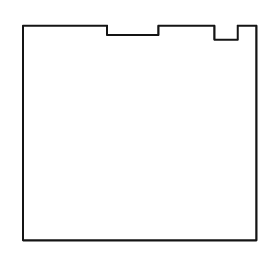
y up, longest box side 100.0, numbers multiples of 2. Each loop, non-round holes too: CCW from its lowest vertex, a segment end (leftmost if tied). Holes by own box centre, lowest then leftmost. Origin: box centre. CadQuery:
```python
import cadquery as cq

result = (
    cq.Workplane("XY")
    .moveTo(-50.0, -46.0)
    .lineTo(50.0, -46.0)
    .lineTo(50.0, 46.0)
    .lineTo(42.0, 46.0)
    .lineTo(42.0, 40.0)
    .lineTo(32.0, 40.0)
    .lineTo(32.0, 46.0)
    .lineTo(8.0, 46.0)
    .lineTo(8.0, 42.0)
    .lineTo(-14.0, 42.0)
    .lineTo(-14.0, 46.0)
    .lineTo(-50.0, 46.0)
    .close()
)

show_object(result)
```